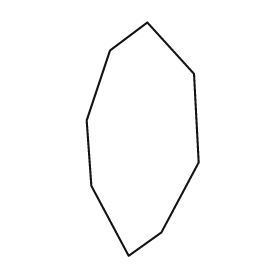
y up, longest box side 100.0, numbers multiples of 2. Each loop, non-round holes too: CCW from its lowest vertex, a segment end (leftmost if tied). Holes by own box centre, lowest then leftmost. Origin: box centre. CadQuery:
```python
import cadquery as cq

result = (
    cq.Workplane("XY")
    .moveTo(-6.0, -50.0)
    .lineTo(8.0, -40.0)
    .lineTo(24.0, -10.0)
    .lineTo(22.0, 28.0)
    .lineTo(2.0, 50.0)
    .lineTo(-14.0, 38.0)
    .lineTo(-24.0, 8.0)
    .lineTo(-22.0, -20.0)
    .close()
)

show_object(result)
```